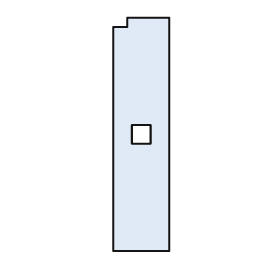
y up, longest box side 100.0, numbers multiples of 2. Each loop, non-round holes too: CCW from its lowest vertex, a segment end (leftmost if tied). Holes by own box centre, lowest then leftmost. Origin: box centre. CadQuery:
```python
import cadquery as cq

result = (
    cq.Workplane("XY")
    .moveTo(-12.0, -50.0)
    .lineTo(12.0, -50.0)
    .lineTo(12.0, 50.0)
    .lineTo(-6.0, 50.0)
    .lineTo(-6.0, 46.0)
    .lineTo(-12.0, 46.0)
    .close()
    .moveTo(-4.0, -4.0)
    .lineTo(4.0, -4.0)
    .lineTo(4.0, 4.0)
    .lineTo(-4.0, 4.0)
    .close()
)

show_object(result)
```